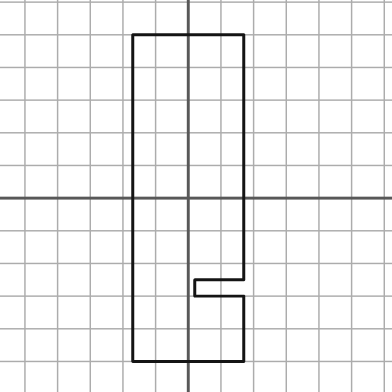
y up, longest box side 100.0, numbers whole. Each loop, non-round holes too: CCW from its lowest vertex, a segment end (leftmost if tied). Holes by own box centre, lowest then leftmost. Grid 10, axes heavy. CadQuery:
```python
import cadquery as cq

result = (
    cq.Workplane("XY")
    .moveTo(-17.0, -50.0)
    .lineTo(17.0, -50.0)
    .lineTo(17.0, -30.0)
    .lineTo(2.0, -30.0)
    .lineTo(2.0, -25.0)
    .lineTo(17.0, -25.0)
    .lineTo(17.0, 50.0)
    .lineTo(-17.0, 50.0)
    .close()
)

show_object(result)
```